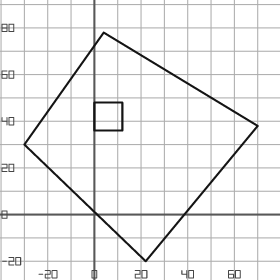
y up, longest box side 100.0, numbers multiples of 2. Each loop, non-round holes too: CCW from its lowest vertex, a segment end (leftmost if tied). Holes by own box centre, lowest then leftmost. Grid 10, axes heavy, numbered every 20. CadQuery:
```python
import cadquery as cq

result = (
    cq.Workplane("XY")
    .moveTo(22.0, -20.0)
    .lineTo(70.0, 38.0)
    .lineTo(4.0, 78.0)
    .lineTo(-30.0, 30.0)
    .close()
    .moveTo(0.0, 36.0)
    .lineTo(12.0, 36.0)
    .lineTo(12.0, 48.0)
    .lineTo(0.0, 48.0)
    .close()
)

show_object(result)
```